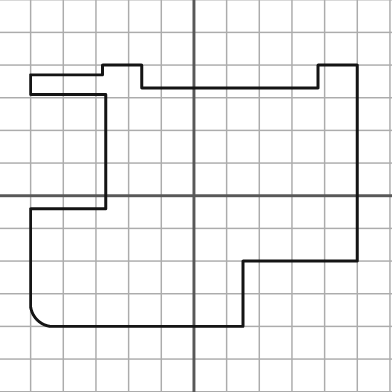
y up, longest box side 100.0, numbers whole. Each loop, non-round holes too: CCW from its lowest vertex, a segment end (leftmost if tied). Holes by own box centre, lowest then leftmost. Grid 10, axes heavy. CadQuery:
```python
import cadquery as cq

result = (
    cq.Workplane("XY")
    .moveTo(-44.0, -40.0)
    .lineTo(15.0, -40.0)
    .lineTo(15.0, -20.0)
    .lineTo(50.0, -20.0)
    .lineTo(50.0, 40.0)
    .lineTo(38.0, 40.0)
    .lineTo(38.0, 33.0)
    .lineTo(-16.0, 33.0)
    .lineTo(-16.0, 40.0)
    .lineTo(-28.0, 40.0)
    .lineTo(-28.0, 37.0)
    .lineTo(-50.0, 37.0)
    .lineTo(-50.0, 31.0)
    .lineTo(-27.0, 31.0)
    .lineTo(-27.0, -4.0)
    .lineTo(-50.0, -4.0)
    .lineTo(-50.0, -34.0)
    .threePointArc((-48.0, -38.0), (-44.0, -40.0))
    .close()
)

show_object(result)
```